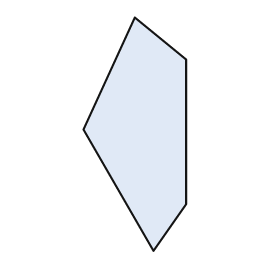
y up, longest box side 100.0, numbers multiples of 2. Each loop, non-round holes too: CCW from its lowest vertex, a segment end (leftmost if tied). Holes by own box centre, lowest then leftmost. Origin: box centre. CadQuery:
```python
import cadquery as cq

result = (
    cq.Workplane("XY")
    .moveTo(8.0, -50.0)
    .lineTo(22.0, -30.0)
    .lineTo(22.0, 32.0)
    .lineTo(0.0, 50.0)
    .lineTo(-22.0, 2.0)
    .close()
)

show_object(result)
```